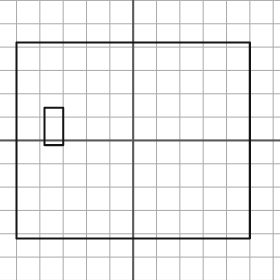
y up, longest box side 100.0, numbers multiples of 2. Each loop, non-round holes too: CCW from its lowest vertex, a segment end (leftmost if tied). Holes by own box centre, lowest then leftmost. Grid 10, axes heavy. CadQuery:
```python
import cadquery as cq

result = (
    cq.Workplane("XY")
    .moveTo(-50.0, -42.0)
    .lineTo(50.0, -42.0)
    .lineTo(50.0, 42.0)
    .lineTo(-50.0, 42.0)
    .close()
    .moveTo(-38.0, -2.0)
    .lineTo(-30.0, -2.0)
    .lineTo(-30.0, 14.0)
    .lineTo(-38.0, 14.0)
    .close()
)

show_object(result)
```